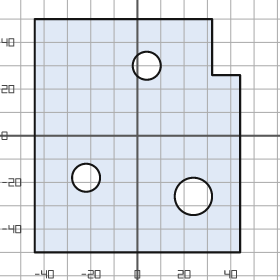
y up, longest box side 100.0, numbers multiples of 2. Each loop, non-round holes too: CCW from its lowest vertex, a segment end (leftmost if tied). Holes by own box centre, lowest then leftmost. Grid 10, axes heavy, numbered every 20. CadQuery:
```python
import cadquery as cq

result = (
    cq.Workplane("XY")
    .moveTo(-44.0, -50.0)
    .lineTo(44.0, -50.0)
    .lineTo(44.0, 26.0)
    .lineTo(32.0, 26.0)
    .lineTo(32.0, 50.0)
    .lineTo(-44.0, 50.0)
    .close()
    .moveTo(24.0, -26.0)
    .circle(8.0)
    .moveTo(-22.0, -18.0)
    .circle(6.0)
    .moveTo(4.0, 30.0)
    .circle(6.0)
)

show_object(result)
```